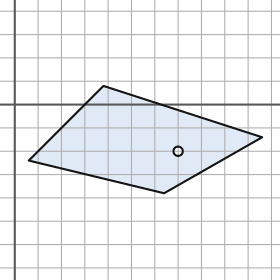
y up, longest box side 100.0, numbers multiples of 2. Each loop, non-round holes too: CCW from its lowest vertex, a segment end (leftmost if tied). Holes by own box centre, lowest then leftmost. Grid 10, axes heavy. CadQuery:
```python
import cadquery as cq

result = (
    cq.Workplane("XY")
    .moveTo(64.0, -38.0)
    .lineTo(106.0, -14.0)
    .lineTo(38.0, 8.0)
    .lineTo(6.0, -24.0)
    .close()
    .moveTo(70.0, -20.0)
    .circle(2.0)
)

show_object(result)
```